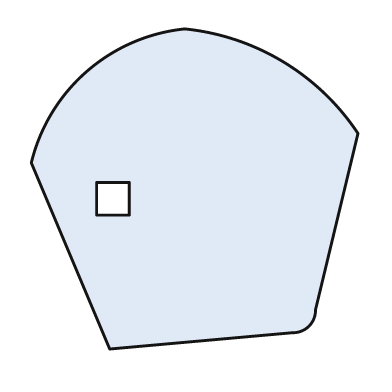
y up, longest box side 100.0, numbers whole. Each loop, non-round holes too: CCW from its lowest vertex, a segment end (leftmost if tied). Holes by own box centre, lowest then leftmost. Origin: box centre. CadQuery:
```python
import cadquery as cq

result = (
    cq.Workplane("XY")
    .moveTo(-26.0, -49.0)
    .lineTo(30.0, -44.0)
    .threePointArc((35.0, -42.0), (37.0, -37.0))
    .lineTo(50.0, 17.0)
    .threePointArc((27.0, 39.0), (-3.0, 49.0))
    .threePointArc((-33.0, 36.0), (-50.0, 8.0))
    .close()
    .moveTo(-30.0, -8.0)
    .lineTo(-20.0, -8.0)
    .lineTo(-20.0, 2.0)
    .lineTo(-30.0, 2.0)
    .close()
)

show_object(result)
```